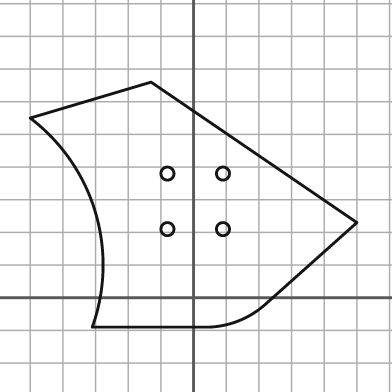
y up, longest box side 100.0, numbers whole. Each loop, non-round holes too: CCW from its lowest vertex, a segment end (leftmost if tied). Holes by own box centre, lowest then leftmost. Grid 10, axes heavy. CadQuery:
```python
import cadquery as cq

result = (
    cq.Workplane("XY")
    .moveTo(-31.0, -9.0)
    .lineTo(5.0, -9.0)
    .threePointArc((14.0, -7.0), (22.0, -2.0))
    .lineTo(50.0, 23.0)
    .lineTo(-13.0, 66.0)
    .lineTo(-50.0, 55.0)
    .threePointArc((-30.0, 26.0), (-31.0, -9.0))
    .close()
    .moveTo(-8.0, 21.0)
    .circle(2.0)
    .moveTo(9.0, 21.0)
    .circle(2.0)
    .moveTo(-8.0, 38.0)
    .circle(2.0)
    .moveTo(9.0, 38.0)
    .circle(2.0)
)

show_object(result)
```